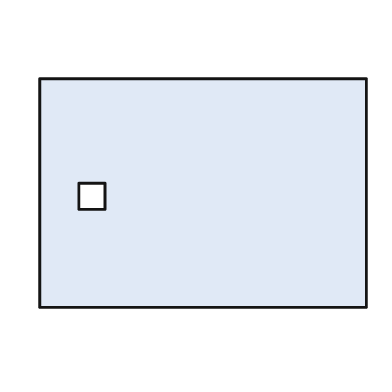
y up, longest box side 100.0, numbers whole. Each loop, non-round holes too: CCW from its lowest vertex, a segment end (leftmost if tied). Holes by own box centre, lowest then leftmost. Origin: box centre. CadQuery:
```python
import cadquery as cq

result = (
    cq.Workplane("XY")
    .moveTo(-50.0, -35.0)
    .lineTo(50.0, -35.0)
    .lineTo(50.0, 35.0)
    .lineTo(-50.0, 35.0)
    .close()
    .moveTo(-38.0, -5.0)
    .lineTo(-30.0, -5.0)
    .lineTo(-30.0, 3.0)
    .lineTo(-38.0, 3.0)
    .close()
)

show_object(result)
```